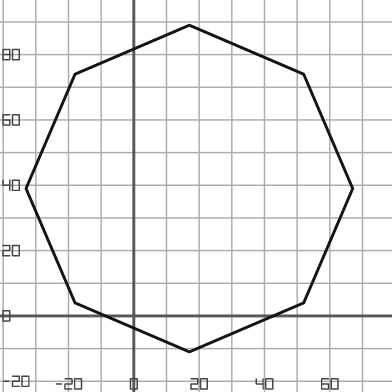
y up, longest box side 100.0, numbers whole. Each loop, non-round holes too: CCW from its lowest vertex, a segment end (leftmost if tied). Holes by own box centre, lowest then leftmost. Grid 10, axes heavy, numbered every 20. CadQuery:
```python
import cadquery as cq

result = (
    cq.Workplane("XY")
    .moveTo(17.0, -11.0)
    .lineTo(52.0, 4.0)
    .lineTo(67.0, 39.0)
    .lineTo(52.0, 74.0)
    .lineTo(17.0, 89.0)
    .lineTo(-18.0, 74.0)
    .lineTo(-33.0, 39.0)
    .lineTo(-18.0, 4.0)
    .close()
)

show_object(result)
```